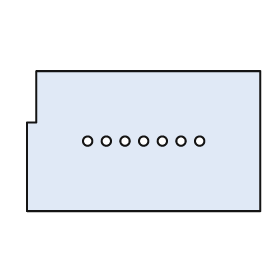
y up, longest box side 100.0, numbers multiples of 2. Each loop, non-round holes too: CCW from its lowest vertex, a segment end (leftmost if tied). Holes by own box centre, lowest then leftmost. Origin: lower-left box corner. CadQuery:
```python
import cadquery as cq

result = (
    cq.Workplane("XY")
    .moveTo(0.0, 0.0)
    .lineTo(100.0, 0.0)
    .lineTo(100.0, 60.0)
    .lineTo(4.0, 60.0)
    .lineTo(4.0, 38.0)
    .lineTo(0.0, 38.0)
    .close()
    .moveTo(26.0, 30.0)
    .circle(2.0)
    .moveTo(34.0, 30.0)
    .circle(2.0)
    .moveTo(42.0, 30.0)
    .circle(2.0)
    .moveTo(50.0, 30.0)
    .circle(2.0)
    .moveTo(58.0, 30.0)
    .circle(2.0)
    .moveTo(66.0, 30.0)
    .circle(2.0)
    .moveTo(74.0, 30.0)
    .circle(2.0)
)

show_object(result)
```